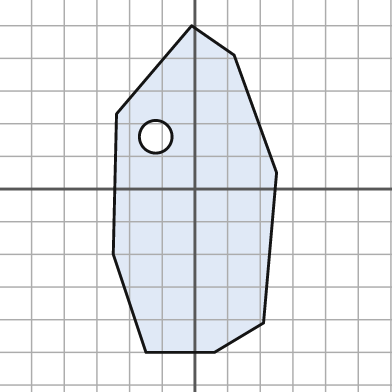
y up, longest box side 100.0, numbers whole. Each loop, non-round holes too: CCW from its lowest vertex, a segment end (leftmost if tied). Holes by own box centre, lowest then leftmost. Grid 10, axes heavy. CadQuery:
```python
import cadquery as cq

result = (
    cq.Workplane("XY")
    .moveTo(-15.0, -50.0)
    .lineTo(6.0, -50.0)
    .lineTo(21.0, -41.0)
    .lineTo(25.0, 5.0)
    .lineTo(12.0, 41.0)
    .lineTo(-1.0, 50.0)
    .lineTo(-24.0, 23.0)
    .lineTo(-25.0, -20.0)
    .close()
    .moveTo(-12.0, 16.0)
    .circle(5.0)
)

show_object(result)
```